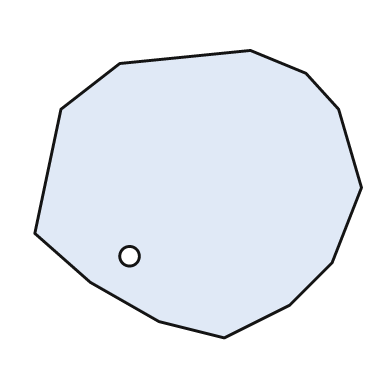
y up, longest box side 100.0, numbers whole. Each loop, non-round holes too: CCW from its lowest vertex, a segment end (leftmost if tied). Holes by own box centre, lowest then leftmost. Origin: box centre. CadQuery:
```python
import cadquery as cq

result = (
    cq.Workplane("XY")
    .moveTo(8.0, -44.0)
    .lineTo(28.0, -34.0)
    .lineTo(41.0, -21.0)
    .lineTo(50.0, 2.0)
    .lineTo(43.0, 26.0)
    .lineTo(33.0, 37.0)
    .lineTo(16.0, 44.0)
    .lineTo(-24.0, 40.0)
    .lineTo(-42.0, 26.0)
    .lineTo(-50.0, -12.0)
    .lineTo(-33.0, -27.0)
    .lineTo(-12.0, -39.0)
    .close()
    .moveTo(-21.0, -19.0)
    .circle(3.0)
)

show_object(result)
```